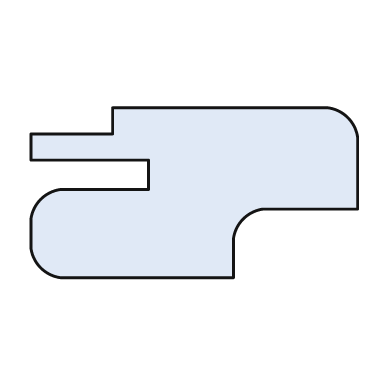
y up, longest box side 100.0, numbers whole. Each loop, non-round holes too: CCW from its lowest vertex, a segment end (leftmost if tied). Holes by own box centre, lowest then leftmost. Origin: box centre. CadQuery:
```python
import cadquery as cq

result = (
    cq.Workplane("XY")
    .moveTo(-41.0, -26.0)
    .lineTo(12.0, -26.0)
    .lineTo(12.0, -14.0)
    .threePointArc((15.0, -8.0), (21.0, -5.0))
    .lineTo(50.0, -5.0)
    .lineTo(50.0, 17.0)
    .threePointArc((47.0, 23.0), (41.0, 26.0))
    .lineTo(-25.0, 26.0)
    .lineTo(-25.0, 18.0)
    .lineTo(-50.0, 18.0)
    .lineTo(-50.0, 10.0)
    .lineTo(-14.0, 10.0)
    .lineTo(-14.0, 1.0)
    .lineTo(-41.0, 1.0)
    .threePointArc((-47.0, -2.0), (-50.0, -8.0))
    .lineTo(-50.0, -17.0)
    .threePointArc((-47.0, -23.0), (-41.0, -26.0))
    .close()
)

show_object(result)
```